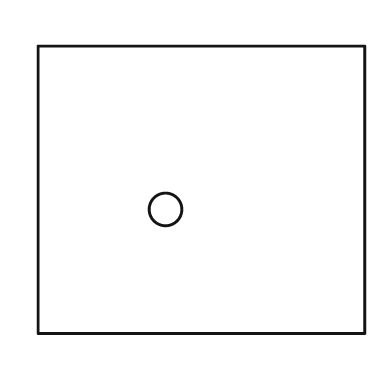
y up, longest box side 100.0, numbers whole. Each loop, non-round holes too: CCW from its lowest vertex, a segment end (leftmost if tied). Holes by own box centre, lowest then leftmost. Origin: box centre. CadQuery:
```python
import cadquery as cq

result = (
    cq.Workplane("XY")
    .moveTo(-50.0, -44.0)
    .lineTo(50.0, -44.0)
    .lineTo(50.0, 44.0)
    .lineTo(-50.0, 44.0)
    .close()
    .moveTo(-11.0, -6.0)
    .circle(5.0)
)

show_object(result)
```